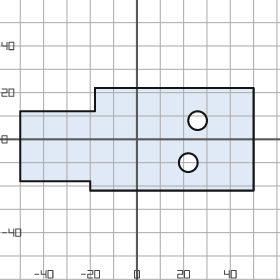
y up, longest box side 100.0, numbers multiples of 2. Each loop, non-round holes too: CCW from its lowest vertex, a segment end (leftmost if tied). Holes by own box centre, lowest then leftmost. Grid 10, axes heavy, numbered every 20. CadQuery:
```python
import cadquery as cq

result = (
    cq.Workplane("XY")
    .moveTo(-20.0, -22.0)
    .lineTo(50.0, -22.0)
    .lineTo(50.0, 22.0)
    .lineTo(-18.0, 22.0)
    .lineTo(-18.0, 12.0)
    .lineTo(-50.0, 12.0)
    .lineTo(-50.0, -18.0)
    .lineTo(-20.0, -18.0)
    .close()
    .moveTo(22.0, -10.0)
    .circle(4.0)
    .moveTo(26.0, 8.0)
    .circle(4.0)
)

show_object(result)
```